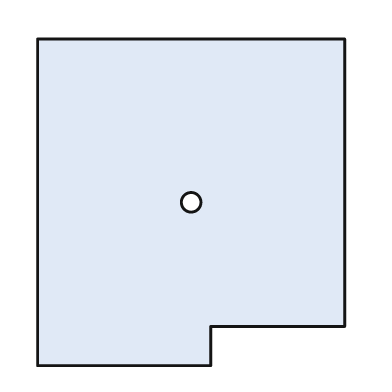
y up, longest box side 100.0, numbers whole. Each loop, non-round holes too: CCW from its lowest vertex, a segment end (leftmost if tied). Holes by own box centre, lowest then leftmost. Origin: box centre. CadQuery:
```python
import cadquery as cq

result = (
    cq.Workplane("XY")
    .moveTo(-47.0, -50.0)
    .lineTo(6.0, -50.0)
    .lineTo(6.0, -38.0)
    .lineTo(47.0, -38.0)
    .lineTo(47.0, 50.0)
    .lineTo(-47.0, 50.0)
    .close()
    .moveTo(0.0, 0.0)
    .circle(3.0)
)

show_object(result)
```